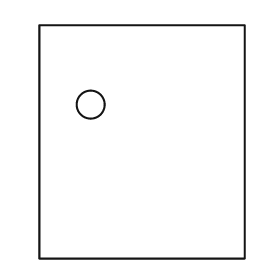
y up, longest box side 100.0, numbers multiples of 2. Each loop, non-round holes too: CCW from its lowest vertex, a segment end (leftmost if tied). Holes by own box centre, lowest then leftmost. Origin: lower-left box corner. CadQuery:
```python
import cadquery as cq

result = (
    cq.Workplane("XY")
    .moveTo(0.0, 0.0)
    .lineTo(88.0, 0.0)
    .lineTo(88.0, 100.0)
    .lineTo(0.0, 100.0)
    .close()
    .moveTo(22.0, 66.0)
    .circle(6.0)
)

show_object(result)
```